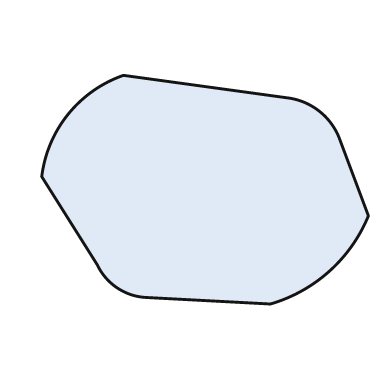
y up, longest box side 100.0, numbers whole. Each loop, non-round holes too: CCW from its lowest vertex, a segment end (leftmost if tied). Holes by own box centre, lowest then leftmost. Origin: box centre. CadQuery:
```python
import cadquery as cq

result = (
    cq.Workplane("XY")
    .moveTo(20.0, -35.0)
    .threePointArc((38.0, -25.0), (50.0, -8.0))
    .lineTo(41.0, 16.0)
    .threePointArc((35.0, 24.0), (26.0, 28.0))
    .lineTo(-25.0, 35.0)
    .threePointArc((-42.0, 23.0), (-50.0, 4.0))
    .lineTo(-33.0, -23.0)
    .threePointArc((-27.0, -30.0), (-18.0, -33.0))
    .close()
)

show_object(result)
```